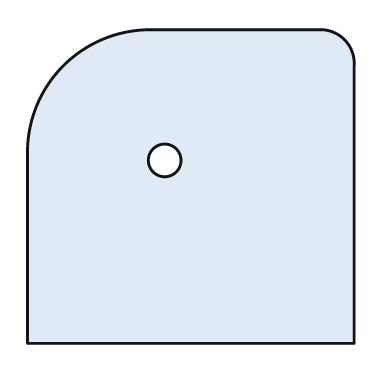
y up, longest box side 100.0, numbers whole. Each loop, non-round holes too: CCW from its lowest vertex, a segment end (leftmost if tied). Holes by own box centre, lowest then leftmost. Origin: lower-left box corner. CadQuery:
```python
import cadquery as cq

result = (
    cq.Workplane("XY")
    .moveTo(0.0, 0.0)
    .lineTo(100.0, 0.0)
    .lineTo(100.0, 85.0)
    .threePointArc((97.0, 93.0), (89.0, 96.0))
    .lineTo(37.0, 96.0)
    .threePointArc((11.0, 85.0), (0.0, 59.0))
    .close()
    .moveTo(42.0, 56.0)
    .circle(5.0)
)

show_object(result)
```